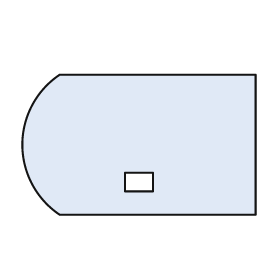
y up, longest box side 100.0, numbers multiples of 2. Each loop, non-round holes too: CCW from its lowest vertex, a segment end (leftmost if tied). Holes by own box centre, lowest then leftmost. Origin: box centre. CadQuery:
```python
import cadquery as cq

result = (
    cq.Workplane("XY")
    .moveTo(-34.0, -30.0)
    .lineTo(50.0, -30.0)
    .lineTo(50.0, 30.0)
    .lineTo(-34.0, 30.0)
    .threePointArc((-50.0, 0.0), (-34.0, -30.0))
    .close()
    .moveTo(-6.0, -20.0)
    .lineTo(6.0, -20.0)
    .lineTo(6.0, -12.0)
    .lineTo(-6.0, -12.0)
    .close()
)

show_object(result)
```